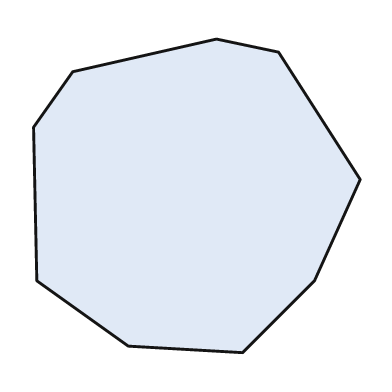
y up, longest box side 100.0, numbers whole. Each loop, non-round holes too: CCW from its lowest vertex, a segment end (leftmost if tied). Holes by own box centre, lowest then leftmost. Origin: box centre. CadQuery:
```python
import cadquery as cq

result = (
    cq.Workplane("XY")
    .moveTo(14.0, -48.0)
    .lineTo(36.0, -26.0)
    .lineTo(50.0, 5.0)
    .lineTo(25.0, 44.0)
    .lineTo(6.0, 48.0)
    .lineTo(-38.0, 38.0)
    .lineTo(-50.0, 21.0)
    .lineTo(-49.0, -26.0)
    .lineTo(-21.0, -46.0)
    .close()
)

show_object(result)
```